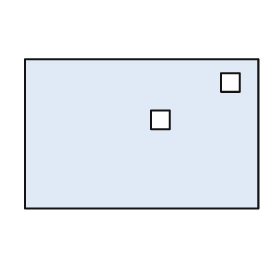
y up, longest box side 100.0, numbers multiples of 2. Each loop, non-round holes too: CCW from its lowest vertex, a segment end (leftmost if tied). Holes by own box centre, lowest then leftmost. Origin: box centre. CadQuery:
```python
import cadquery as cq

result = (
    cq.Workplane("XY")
    .moveTo(-50.0, -32.0)
    .lineTo(50.0, -32.0)
    .lineTo(50.0, 32.0)
    .lineTo(-50.0, 32.0)
    .close()
    .moveTo(4.0, 2.0)
    .lineTo(12.0, 2.0)
    .lineTo(12.0, 10.0)
    .lineTo(4.0, 10.0)
    .close()
    .moveTo(34.0, 18.0)
    .lineTo(42.0, 18.0)
    .lineTo(42.0, 26.0)
    .lineTo(34.0, 26.0)
    .close()
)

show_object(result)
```